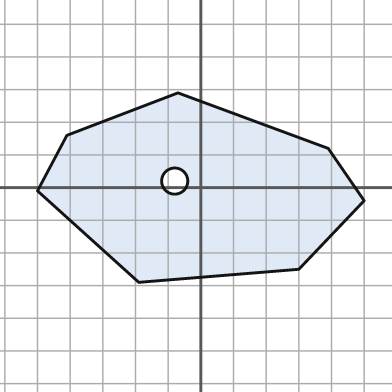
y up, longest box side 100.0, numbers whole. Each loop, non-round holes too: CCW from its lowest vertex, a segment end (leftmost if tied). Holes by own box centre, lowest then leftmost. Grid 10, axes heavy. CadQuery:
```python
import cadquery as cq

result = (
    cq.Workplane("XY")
    .moveTo(-19.0, -29.0)
    .lineTo(30.0, -25.0)
    .lineTo(50.0, -4.0)
    .lineTo(39.0, 12.0)
    .lineTo(-7.0, 29.0)
    .lineTo(-41.0, 16.0)
    .lineTo(-50.0, -1.0)
    .close()
    .moveTo(-8.0, 2.0)
    .circle(4.0)
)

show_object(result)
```